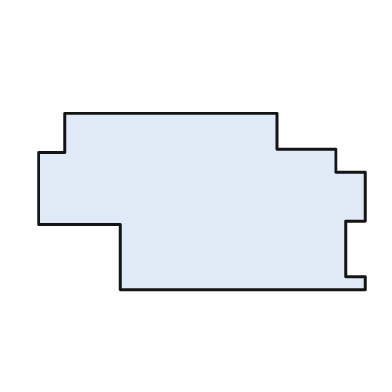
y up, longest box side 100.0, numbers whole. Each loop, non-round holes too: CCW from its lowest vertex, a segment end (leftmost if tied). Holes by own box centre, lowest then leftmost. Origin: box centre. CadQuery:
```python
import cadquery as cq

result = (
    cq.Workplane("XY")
    .moveTo(-25.0, -27.0)
    .lineTo(50.0, -27.0)
    .lineTo(50.0, -23.0)
    .lineTo(44.0, -23.0)
    .lineTo(44.0, -6.0)
    .lineTo(50.0, -6.0)
    .lineTo(50.0, 9.0)
    .lineTo(41.0, 9.0)
    .lineTo(41.0, 16.0)
    .lineTo(23.0, 16.0)
    .lineTo(23.0, 27.0)
    .lineTo(-42.0, 27.0)
    .lineTo(-42.0, 15.0)
    .lineTo(-50.0, 15.0)
    .lineTo(-50.0, -7.0)
    .lineTo(-25.0, -7.0)
    .close()
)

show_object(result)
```